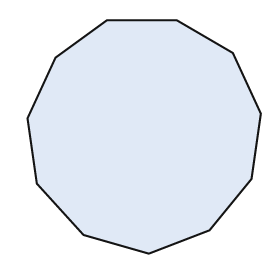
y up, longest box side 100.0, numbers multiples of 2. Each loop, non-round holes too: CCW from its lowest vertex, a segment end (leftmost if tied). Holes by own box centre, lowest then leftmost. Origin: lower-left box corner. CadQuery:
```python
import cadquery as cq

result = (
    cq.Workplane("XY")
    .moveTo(52.0, 0.0)
    .lineTo(78.0, 10.0)
    .lineTo(96.0, 32.0)
    .lineTo(100.0, 60.0)
    .lineTo(88.0, 86.0)
    .lineTo(64.0, 100.0)
    .lineTo(34.0, 100.0)
    .lineTo(12.0, 84.0)
    .lineTo(0.0, 58.0)
    .lineTo(4.0, 30.0)
    .lineTo(24.0, 8.0)
    .close()
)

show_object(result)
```